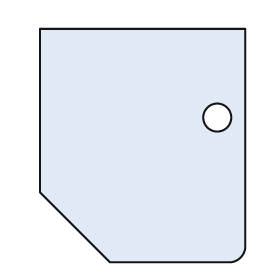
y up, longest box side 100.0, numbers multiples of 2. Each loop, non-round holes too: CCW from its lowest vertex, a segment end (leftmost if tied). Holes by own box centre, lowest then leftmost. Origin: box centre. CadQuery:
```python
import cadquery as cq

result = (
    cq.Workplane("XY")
    .moveTo(-14.0, -50.0)
    .lineTo(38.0, -50.0)
    .threePointArc((42.0, -48.0), (44.0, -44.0))
    .lineTo(44.0, 50.0)
    .lineTo(-44.0, 50.0)
    .lineTo(-44.0, -20.0)
    .close()
    .moveTo(32.0, 12.0)
    .circle(6.0)
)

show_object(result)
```